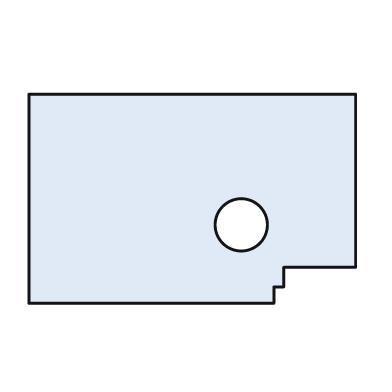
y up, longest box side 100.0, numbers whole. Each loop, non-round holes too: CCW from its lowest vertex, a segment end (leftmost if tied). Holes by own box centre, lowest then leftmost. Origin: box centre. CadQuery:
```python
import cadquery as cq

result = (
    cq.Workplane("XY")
    .moveTo(-50.0, -32.0)
    .lineTo(25.0, -32.0)
    .lineTo(25.0, -27.0)
    .lineTo(28.0, -27.0)
    .lineTo(28.0, -21.0)
    .lineTo(50.0, -21.0)
    .lineTo(50.0, 32.0)
    .lineTo(-50.0, 32.0)
    .close()
    .moveTo(15.0, -8.0)
    .circle(8.0)
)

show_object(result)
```